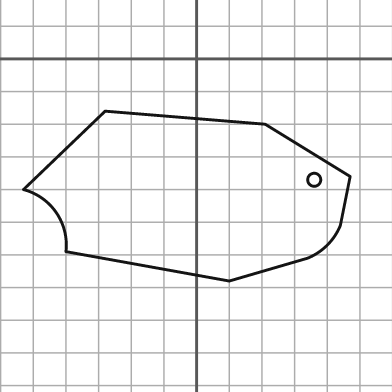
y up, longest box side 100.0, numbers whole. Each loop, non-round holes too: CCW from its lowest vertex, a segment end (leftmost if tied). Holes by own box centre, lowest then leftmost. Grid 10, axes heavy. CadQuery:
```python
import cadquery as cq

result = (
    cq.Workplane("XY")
    .moveTo(10.0, -68.0)
    .lineTo(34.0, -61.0)
    .threePointArc((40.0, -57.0), (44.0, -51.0))
    .lineTo(47.0, -36.0)
    .lineTo(21.0, -20.0)
    .lineTo(-28.0, -16.0)
    .lineTo(-53.0, -40.0)
    .threePointArc((-43.0, -47.0), (-40.0, -59.0))
    .close()
    .moveTo(36.0, -37.0)
    .circle(2.0)
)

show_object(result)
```